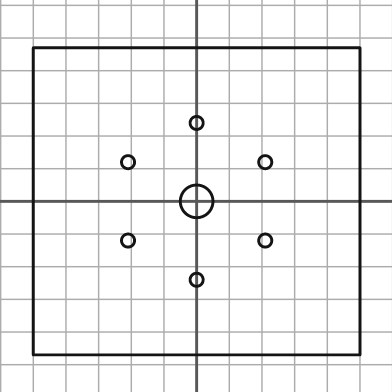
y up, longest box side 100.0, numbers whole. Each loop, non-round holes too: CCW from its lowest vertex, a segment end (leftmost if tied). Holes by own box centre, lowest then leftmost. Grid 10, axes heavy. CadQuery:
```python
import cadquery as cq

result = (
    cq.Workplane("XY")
    .moveTo(-50.0, -47.0)
    .lineTo(50.0, -47.0)
    .lineTo(50.0, 47.0)
    .lineTo(-50.0, 47.0)
    .close()
    .moveTo(0.0, -24.0)
    .circle(2.0)
    .moveTo(-21.0, -12.0)
    .circle(2.0)
    .moveTo(21.0, -12.0)
    .circle(2.0)
    .moveTo(0.0, 0.0)
    .circle(5.0)
    .moveTo(-21.0, 12.0)
    .circle(2.0)
    .moveTo(21.0, 12.0)
    .circle(2.0)
    .moveTo(0.0, 24.0)
    .circle(2.0)
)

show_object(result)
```